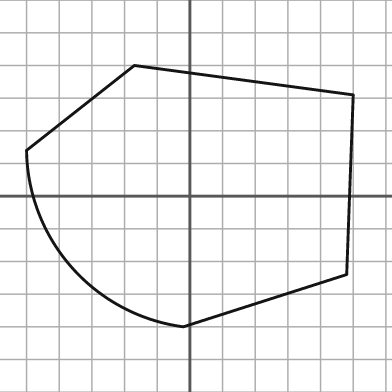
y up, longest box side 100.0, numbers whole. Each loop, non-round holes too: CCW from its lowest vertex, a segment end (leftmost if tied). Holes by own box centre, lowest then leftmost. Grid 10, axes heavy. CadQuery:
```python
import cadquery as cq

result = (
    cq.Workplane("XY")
    .moveTo(-2.0, -40.0)
    .lineTo(48.0, -24.0)
    .lineTo(50.0, 31.0)
    .lineTo(-17.0, 40.0)
    .lineTo(-50.0, 14.0)
    .threePointArc((-36.0, -22.0), (-2.0, -40.0))
    .close()
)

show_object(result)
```